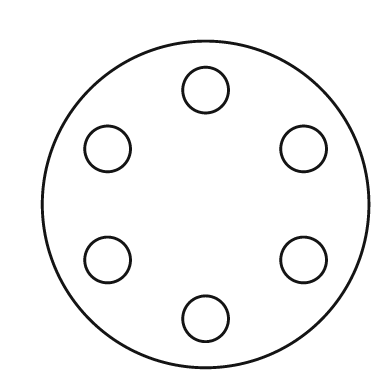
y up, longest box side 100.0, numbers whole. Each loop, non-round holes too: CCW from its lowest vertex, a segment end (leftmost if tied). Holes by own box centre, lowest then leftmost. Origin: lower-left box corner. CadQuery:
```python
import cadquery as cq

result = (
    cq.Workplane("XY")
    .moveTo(50.0, 50.0)
    .circle(50.0)
    .moveTo(50.0, 15.0)
    .circle(7.0)
    .moveTo(20.0, 33.0)
    .circle(7.0)
    .moveTo(80.0, 33.0)
    .circle(7.0)
    .moveTo(20.0, 67.0)
    .circle(7.0)
    .moveTo(80.0, 67.0)
    .circle(7.0)
    .moveTo(50.0, 85.0)
    .circle(7.0)
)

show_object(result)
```